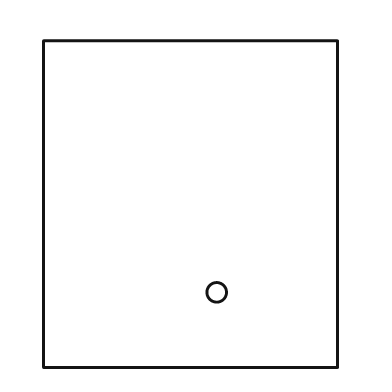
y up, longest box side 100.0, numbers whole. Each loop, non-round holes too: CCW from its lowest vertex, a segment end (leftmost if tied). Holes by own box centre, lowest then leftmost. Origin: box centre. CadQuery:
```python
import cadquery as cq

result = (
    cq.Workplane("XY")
    .moveTo(-45.0, -50.0)
    .lineTo(45.0, -50.0)
    .lineTo(45.0, 50.0)
    .lineTo(-45.0, 50.0)
    .close()
    .moveTo(8.0, -27.0)
    .circle(3.0)
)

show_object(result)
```